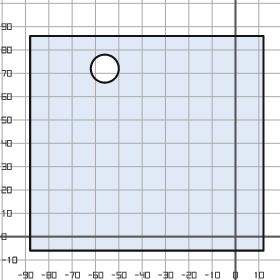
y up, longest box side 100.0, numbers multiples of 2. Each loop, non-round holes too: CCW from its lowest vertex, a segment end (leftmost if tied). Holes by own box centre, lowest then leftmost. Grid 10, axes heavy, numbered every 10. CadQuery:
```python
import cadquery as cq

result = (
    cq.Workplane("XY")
    .moveTo(-88.0, -6.0)
    .lineTo(12.0, -6.0)
    .lineTo(12.0, 86.0)
    .lineTo(-88.0, 86.0)
    .close()
    .moveTo(-56.0, 72.0)
    .circle(6.0)
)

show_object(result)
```